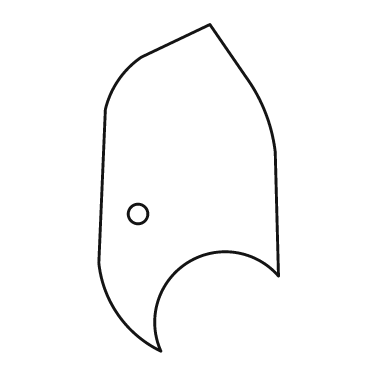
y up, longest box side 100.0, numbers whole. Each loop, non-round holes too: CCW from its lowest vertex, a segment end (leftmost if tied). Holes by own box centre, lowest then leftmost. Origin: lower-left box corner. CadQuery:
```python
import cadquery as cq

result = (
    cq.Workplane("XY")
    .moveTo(19.0, 0.0)
    .threePointArc((27.0, 27.0), (55.0, 23.0))
    .lineTo(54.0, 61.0)
    .threePointArc((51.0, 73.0), (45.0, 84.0))
    .lineTo(34.0, 100.0)
    .lineTo(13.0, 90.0)
    .threePointArc((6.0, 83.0), (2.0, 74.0))
    .lineTo(0.0, 27.0)
    .threePointArc((6.0, 11.0), (19.0, 0.0))
    .close()
    .moveTo(12.0, 42.0)
    .circle(3.0)
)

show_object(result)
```